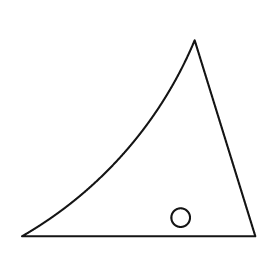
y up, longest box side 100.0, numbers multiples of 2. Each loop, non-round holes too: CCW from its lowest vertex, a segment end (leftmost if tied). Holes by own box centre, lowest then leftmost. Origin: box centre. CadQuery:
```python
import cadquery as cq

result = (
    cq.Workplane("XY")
    .moveTo(-50.0, -42.0)
    .lineTo(50.0, -42.0)
    .lineTo(24.0, 42.0)
    .threePointArc((-6.0, -6.0), (-50.0, -42.0))
    .close()
    .moveTo(18.0, -34.0)
    .circle(4.0)
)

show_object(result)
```